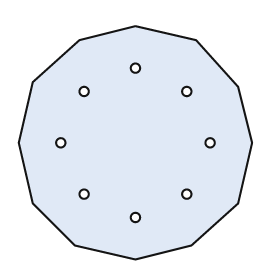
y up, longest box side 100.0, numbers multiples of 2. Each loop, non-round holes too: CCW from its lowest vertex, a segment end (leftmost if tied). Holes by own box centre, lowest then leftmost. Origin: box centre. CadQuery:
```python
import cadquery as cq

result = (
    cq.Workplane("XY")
    .moveTo(0.0, -50.0)
    .lineTo(24.0, -44.0)
    .lineTo(44.0, -26.0)
    .lineTo(50.0, 0.0)
    .lineTo(44.0, 24.0)
    .lineTo(26.0, 44.0)
    .lineTo(0.0, 50.0)
    .lineTo(-24.0, 44.0)
    .lineTo(-44.0, 26.0)
    .lineTo(-50.0, 0.0)
    .lineTo(-44.0, -26.0)
    .lineTo(-26.0, -44.0)
    .close()
    .moveTo(0.0, -32.0)
    .circle(2.0)
    .moveTo(-22.0, -22.0)
    .circle(2.0)
    .moveTo(22.0, -22.0)
    .circle(2.0)
    .moveTo(-32.0, 0.0)
    .circle(2.0)
    .moveTo(32.0, 0.0)
    .circle(2.0)
    .moveTo(-22.0, 22.0)
    .circle(2.0)
    .moveTo(22.0, 22.0)
    .circle(2.0)
    .moveTo(0.0, 32.0)
    .circle(2.0)
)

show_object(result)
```